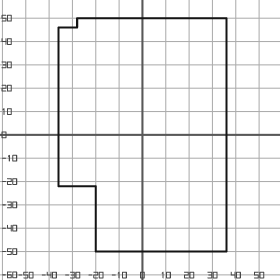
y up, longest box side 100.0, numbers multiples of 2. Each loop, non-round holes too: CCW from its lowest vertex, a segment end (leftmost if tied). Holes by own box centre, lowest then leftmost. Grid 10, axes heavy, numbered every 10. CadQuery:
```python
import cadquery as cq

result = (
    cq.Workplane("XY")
    .moveTo(-20.0, -50.0)
    .lineTo(36.0, -50.0)
    .lineTo(36.0, 50.0)
    .lineTo(-28.0, 50.0)
    .lineTo(-28.0, 46.0)
    .lineTo(-36.0, 46.0)
    .lineTo(-36.0, -22.0)
    .lineTo(-20.0, -22.0)
    .close()
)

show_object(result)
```